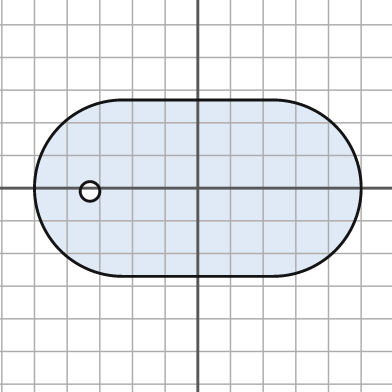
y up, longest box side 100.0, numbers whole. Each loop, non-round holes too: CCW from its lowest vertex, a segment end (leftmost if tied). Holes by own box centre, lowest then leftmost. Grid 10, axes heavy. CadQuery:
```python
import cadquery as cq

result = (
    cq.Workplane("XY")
    .moveTo(-23.0, -27.0)
    .lineTo(23.0, -27.0)
    .threePointArc((50.0, 0.0), (23.0, 27.0))
    .lineTo(-23.0, 27.0)
    .threePointArc((-50.0, 0.0), (-23.0, -27.0))
    .close()
    .moveTo(-33.0, -1.0)
    .circle(3.0)
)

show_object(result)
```